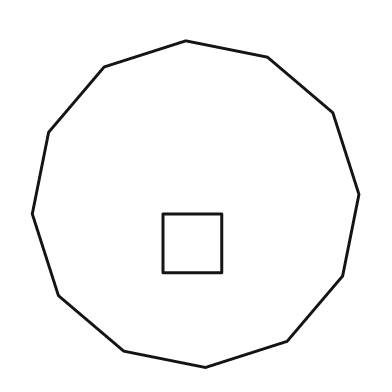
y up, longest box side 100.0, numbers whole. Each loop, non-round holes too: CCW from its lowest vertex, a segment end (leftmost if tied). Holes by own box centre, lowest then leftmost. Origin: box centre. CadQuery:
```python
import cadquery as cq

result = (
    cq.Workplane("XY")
    .moveTo(3.0, -50.0)
    .lineTo(28.0, -42.0)
    .lineTo(45.0, -22.0)
    .lineTo(50.0, 3.0)
    .lineTo(42.0, 28.0)
    .lineTo(22.0, 45.0)
    .lineTo(-3.0, 50.0)
    .lineTo(-28.0, 42.0)
    .lineTo(-45.0, 22.0)
    .lineTo(-50.0, -3.0)
    .lineTo(-42.0, -28.0)
    .lineTo(-22.0, -45.0)
    .close()
    .moveTo(-10.0, -21.0)
    .lineTo(8.0, -21.0)
    .lineTo(8.0, -3.0)
    .lineTo(-10.0, -3.0)
    .close()
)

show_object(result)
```